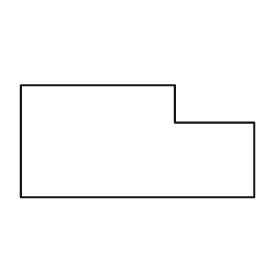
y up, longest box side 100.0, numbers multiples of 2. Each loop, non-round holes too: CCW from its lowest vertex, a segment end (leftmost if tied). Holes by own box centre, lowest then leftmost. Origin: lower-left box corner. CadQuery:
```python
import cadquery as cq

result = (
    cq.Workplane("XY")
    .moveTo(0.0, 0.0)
    .lineTo(100.0, 0.0)
    .lineTo(100.0, 32.0)
    .lineTo(66.0, 32.0)
    .lineTo(66.0, 48.0)
    .lineTo(0.0, 48.0)
    .close()
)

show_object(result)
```